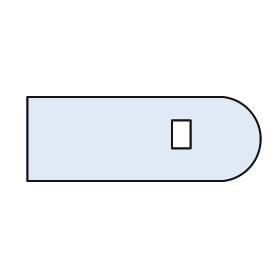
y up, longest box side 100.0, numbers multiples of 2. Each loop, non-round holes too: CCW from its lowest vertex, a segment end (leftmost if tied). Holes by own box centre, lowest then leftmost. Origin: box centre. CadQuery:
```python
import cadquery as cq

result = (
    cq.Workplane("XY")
    .moveTo(-50.0, -18.0)
    .lineTo(34.0, -18.0)
    .threePointArc((50.0, 0.0), (34.0, 18.0))
    .lineTo(-50.0, 18.0)
    .close()
    .moveTo(12.0, -4.0)
    .lineTo(20.0, -4.0)
    .lineTo(20.0, 8.0)
    .lineTo(12.0, 8.0)
    .close()
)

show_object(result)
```